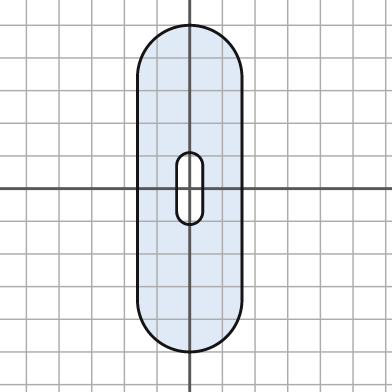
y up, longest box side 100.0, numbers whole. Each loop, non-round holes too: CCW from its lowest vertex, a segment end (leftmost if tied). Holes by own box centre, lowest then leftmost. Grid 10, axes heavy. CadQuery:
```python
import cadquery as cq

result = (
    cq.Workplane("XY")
    .moveTo(-16.0, -34.0)
    .threePointArc((0.0, -50.0), (16.0, -34.0))
    .lineTo(16.0, 34.0)
    .threePointArc((0.0, 50.0), (-16.0, 34.0))
    .close()
    .moveTo(-4.0, -7.0)
    .threePointArc((0.0, -11.0), (4.0, -7.0))
    .lineTo(4.0, 7.0)
    .threePointArc((0.0, 11.0), (-4.0, 7.0))
    .close()
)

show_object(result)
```